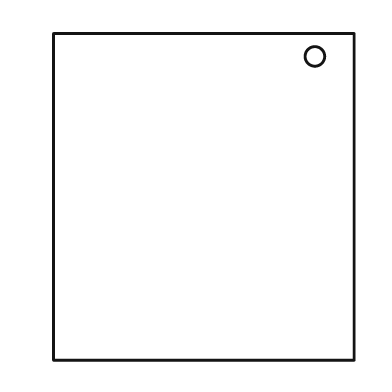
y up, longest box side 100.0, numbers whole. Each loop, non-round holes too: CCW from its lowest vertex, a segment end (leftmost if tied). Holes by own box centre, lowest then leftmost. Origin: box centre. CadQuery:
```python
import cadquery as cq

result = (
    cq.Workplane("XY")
    .moveTo(-46.0, -50.0)
    .lineTo(46.0, -50.0)
    .lineTo(46.0, 50.0)
    .lineTo(-46.0, 50.0)
    .close()
    .moveTo(34.0, 43.0)
    .circle(3.0)
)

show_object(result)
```